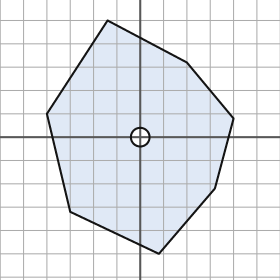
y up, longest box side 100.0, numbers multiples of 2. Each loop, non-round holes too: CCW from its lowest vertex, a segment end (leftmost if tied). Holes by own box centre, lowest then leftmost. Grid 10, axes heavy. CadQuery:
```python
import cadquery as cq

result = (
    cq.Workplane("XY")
    .moveTo(8.0, -50.0)
    .lineTo(32.0, -22.0)
    .lineTo(40.0, 8.0)
    .lineTo(20.0, 32.0)
    .lineTo(-14.0, 50.0)
    .lineTo(-40.0, 10.0)
    .lineTo(-30.0, -32.0)
    .close()
    .moveTo(0.0, 0.0)
    .circle(4.0)
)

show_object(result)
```